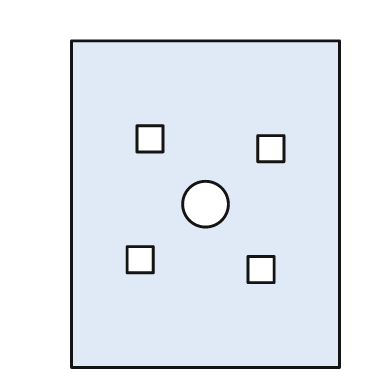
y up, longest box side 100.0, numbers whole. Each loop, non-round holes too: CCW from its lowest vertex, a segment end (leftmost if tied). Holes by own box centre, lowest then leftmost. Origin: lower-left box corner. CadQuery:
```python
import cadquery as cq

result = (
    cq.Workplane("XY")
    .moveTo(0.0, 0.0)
    .lineTo(82.0, 0.0)
    .lineTo(82.0, 100.0)
    .lineTo(0.0, 100.0)
    .close()
    .moveTo(54.0, 26.0)
    .lineTo(62.0, 26.0)
    .lineTo(62.0, 34.0)
    .lineTo(54.0, 34.0)
    .close()
    .moveTo(17.0, 29.0)
    .lineTo(25.0, 29.0)
    .lineTo(25.0, 37.0)
    .lineTo(17.0, 37.0)
    .close()
    .moveTo(41.0, 50.0)
    .circle(7.0)
    .moveTo(57.0, 63.0)
    .lineTo(65.0, 63.0)
    .lineTo(65.0, 71.0)
    .lineTo(57.0, 71.0)
    .close()
    .moveTo(20.0, 66.0)
    .lineTo(28.0, 66.0)
    .lineTo(28.0, 74.0)
    .lineTo(20.0, 74.0)
    .close()
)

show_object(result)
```